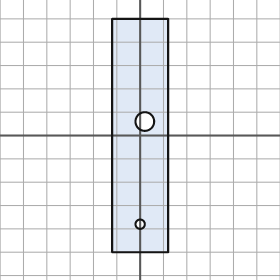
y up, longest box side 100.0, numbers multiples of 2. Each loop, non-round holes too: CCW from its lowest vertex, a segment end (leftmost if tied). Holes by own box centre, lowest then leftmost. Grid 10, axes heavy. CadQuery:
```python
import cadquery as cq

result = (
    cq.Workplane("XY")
    .moveTo(-12.0, -50.0)
    .lineTo(12.0, -50.0)
    .lineTo(12.0, 50.0)
    .lineTo(-12.0, 50.0)
    .close()
    .moveTo(0.0, -38.0)
    .circle(2.0)
    .moveTo(2.0, 6.0)
    .circle(4.0)
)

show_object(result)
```